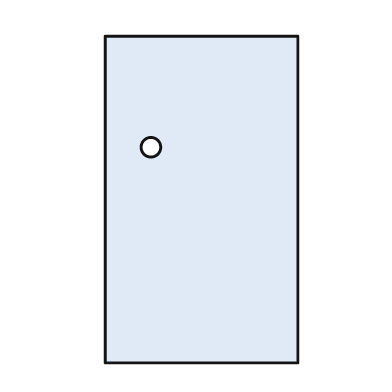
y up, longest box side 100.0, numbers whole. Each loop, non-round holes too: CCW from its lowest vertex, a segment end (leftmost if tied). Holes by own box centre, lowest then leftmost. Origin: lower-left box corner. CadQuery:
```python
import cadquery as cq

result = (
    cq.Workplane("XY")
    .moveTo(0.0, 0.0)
    .lineTo(59.0, 0.0)
    .lineTo(59.0, 100.0)
    .lineTo(0.0, 100.0)
    .close()
    .moveTo(14.0, 66.0)
    .circle(3.0)
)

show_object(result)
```